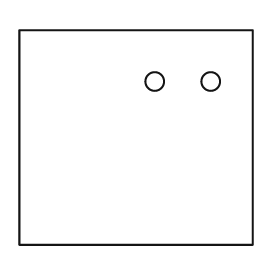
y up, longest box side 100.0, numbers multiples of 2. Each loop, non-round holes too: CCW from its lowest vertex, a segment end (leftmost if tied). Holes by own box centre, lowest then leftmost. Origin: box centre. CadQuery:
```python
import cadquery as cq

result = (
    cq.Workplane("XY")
    .moveTo(-50.0, -46.0)
    .lineTo(50.0, -46.0)
    .lineTo(50.0, 46.0)
    .lineTo(-50.0, 46.0)
    .close()
    .moveTo(8.0, 24.0)
    .circle(4.0)
    .moveTo(32.0, 24.0)
    .circle(4.0)
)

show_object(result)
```